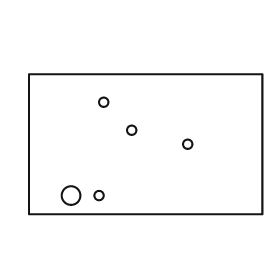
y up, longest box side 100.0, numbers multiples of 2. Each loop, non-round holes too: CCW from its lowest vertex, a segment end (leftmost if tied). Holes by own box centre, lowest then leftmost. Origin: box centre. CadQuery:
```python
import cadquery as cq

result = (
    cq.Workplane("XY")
    .moveTo(-50.0, -30.0)
    .lineTo(50.0, -30.0)
    .lineTo(50.0, 30.0)
    .lineTo(-50.0, 30.0)
    .close()
    .moveTo(-32.0, -22.0)
    .circle(4.0)
    .moveTo(-20.0, -22.0)
    .circle(2.0)
    .moveTo(18.0, 0.0)
    .circle(2.0)
    .moveTo(-6.0, 6.0)
    .circle(2.0)
    .moveTo(-18.0, 18.0)
    .circle(2.0)
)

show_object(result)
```